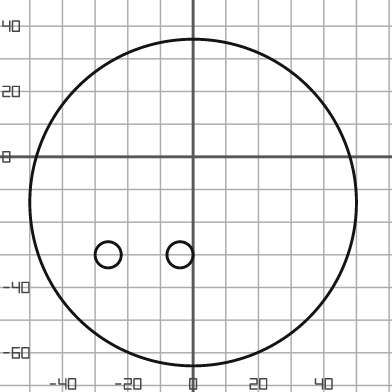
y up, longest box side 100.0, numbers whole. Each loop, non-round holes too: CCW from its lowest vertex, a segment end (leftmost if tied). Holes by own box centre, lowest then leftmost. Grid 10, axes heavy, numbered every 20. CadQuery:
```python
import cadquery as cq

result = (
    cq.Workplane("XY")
    .moveTo(0.0, -14.0)
    .circle(50.0)
    .moveTo(-26.0, -30.0)
    .circle(4.0)
    .moveTo(-4.0, -30.0)
    .circle(4.0)
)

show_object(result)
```